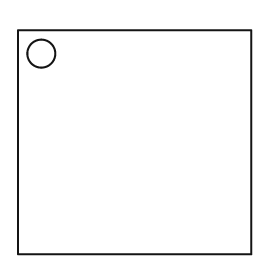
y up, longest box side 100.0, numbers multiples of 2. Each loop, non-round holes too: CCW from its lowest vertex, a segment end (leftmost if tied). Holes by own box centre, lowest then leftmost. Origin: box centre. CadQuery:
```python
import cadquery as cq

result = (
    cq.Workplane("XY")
    .moveTo(-50.0, -48.0)
    .lineTo(50.0, -48.0)
    .lineTo(50.0, 48.0)
    .lineTo(-50.0, 48.0)
    .close()
    .moveTo(-40.0, 38.0)
    .circle(6.0)
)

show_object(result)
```